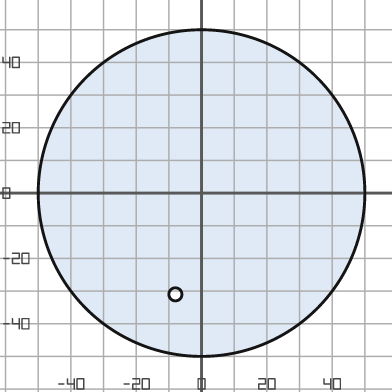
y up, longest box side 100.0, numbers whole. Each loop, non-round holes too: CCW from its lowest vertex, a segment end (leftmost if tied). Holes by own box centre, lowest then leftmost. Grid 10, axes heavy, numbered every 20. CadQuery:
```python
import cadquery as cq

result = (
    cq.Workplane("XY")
    .moveTo(0.0, 0.0)
    .circle(50.0)
    .moveTo(-8.0, -31.0)
    .circle(2.0)
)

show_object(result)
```